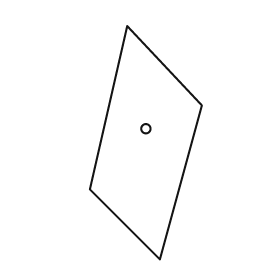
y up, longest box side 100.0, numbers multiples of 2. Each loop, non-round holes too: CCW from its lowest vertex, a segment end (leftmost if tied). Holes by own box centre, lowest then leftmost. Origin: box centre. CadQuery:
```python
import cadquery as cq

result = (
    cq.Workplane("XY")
    .moveTo(6.0, -50.0)
    .lineTo(24.0, 16.0)
    .lineTo(-8.0, 50.0)
    .lineTo(-24.0, -20.0)
    .close()
    .moveTo(0.0, 6.0)
    .circle(2.0)
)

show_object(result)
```